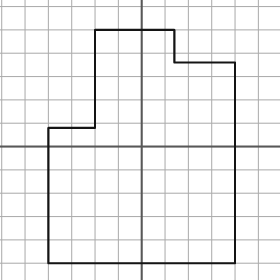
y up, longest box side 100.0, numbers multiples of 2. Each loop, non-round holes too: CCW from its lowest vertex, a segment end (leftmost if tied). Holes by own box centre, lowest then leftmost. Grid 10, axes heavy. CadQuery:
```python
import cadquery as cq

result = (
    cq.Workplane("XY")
    .moveTo(-40.0, -50.0)
    .lineTo(40.0, -50.0)
    .lineTo(40.0, 36.0)
    .lineTo(14.0, 36.0)
    .lineTo(14.0, 50.0)
    .lineTo(-20.0, 50.0)
    .lineTo(-20.0, 8.0)
    .lineTo(-40.0, 8.0)
    .close()
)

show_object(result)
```